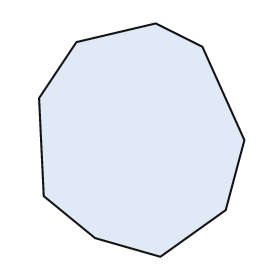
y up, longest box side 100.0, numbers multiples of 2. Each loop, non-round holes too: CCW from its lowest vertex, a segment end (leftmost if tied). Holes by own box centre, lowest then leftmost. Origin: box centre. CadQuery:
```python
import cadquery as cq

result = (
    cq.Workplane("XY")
    .moveTo(8.0, -50.0)
    .lineTo(36.0, -30.0)
    .lineTo(44.0, 0.0)
    .lineTo(26.0, 40.0)
    .lineTo(6.0, 50.0)
    .lineTo(-28.0, 42.0)
    .lineTo(-44.0, 18.0)
    .lineTo(-42.0, -24.0)
    .lineTo(-20.0, -42.0)
    .close()
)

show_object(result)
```